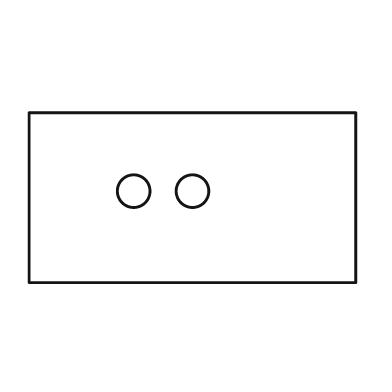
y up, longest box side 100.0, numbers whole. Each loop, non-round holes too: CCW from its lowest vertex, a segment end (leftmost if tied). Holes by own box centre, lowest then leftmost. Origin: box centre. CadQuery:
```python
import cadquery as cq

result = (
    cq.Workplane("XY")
    .moveTo(-50.0, -26.0)
    .lineTo(50.0, -26.0)
    .lineTo(50.0, 26.0)
    .lineTo(-50.0, 26.0)
    .close()
    .moveTo(-18.0, 2.0)
    .circle(5.0)
    .moveTo(0.0, 2.0)
    .circle(5.0)
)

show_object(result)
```